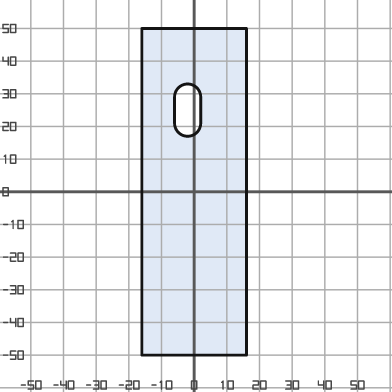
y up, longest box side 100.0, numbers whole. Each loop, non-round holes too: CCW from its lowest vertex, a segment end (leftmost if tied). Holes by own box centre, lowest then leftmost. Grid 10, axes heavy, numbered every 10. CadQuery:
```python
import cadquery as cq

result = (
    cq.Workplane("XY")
    .moveTo(-16.0, -50.0)
    .lineTo(16.0, -50.0)
    .lineTo(16.0, 50.0)
    .lineTo(-16.0, 50.0)
    .close()
    .moveTo(-6.0, 21.0)
    .threePointArc((-2.0, 17.0), (2.0, 21.0))
    .lineTo(2.0, 29.0)
    .threePointArc((-2.0, 33.0), (-6.0, 29.0))
    .close()
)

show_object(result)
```